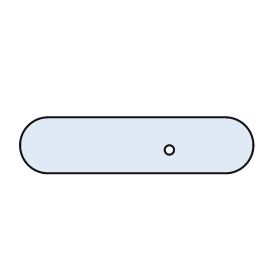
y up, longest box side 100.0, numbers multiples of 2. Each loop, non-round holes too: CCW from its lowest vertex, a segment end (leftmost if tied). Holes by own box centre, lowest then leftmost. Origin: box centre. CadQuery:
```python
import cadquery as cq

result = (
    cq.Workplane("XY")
    .moveTo(-38.0, -12.0)
    .lineTo(38.0, -12.0)
    .threePointArc((50.0, 0.0), (38.0, 12.0))
    .lineTo(-38.0, 12.0)
    .threePointArc((-50.0, 0.0), (-38.0, -12.0))
    .close()
    .moveTo(14.0, -2.0)
    .circle(2.0)
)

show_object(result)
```